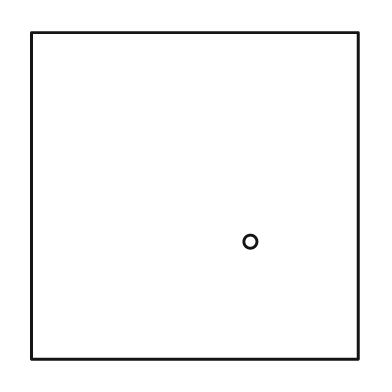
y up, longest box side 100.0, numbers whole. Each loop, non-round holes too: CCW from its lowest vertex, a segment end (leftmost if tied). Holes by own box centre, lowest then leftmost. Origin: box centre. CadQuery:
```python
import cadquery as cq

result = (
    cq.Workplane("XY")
    .moveTo(-50.0, -50.0)
    .lineTo(50.0, -50.0)
    .lineTo(50.0, 50.0)
    .lineTo(-50.0, 50.0)
    .close()
    .moveTo(17.0, -14.0)
    .circle(2.0)
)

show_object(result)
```